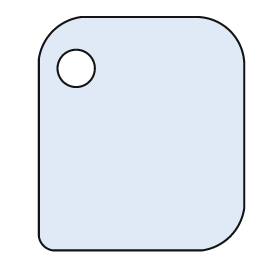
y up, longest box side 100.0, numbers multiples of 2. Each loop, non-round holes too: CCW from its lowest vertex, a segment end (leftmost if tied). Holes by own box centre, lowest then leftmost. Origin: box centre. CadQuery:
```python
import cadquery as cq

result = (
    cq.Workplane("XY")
    .moveTo(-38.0, -50.0)
    .lineTo(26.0, -50.0)
    .threePointArc((38.0, -44.0), (44.0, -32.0))
    .lineTo(44.0, 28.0)
    .threePointArc((38.0, 44.0), (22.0, 50.0))
    .lineTo(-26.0, 50.0)
    .threePointArc((-38.0, 44.0), (-44.0, 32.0))
    .lineTo(-44.0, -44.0)
    .threePointArc((-42.0, -48.0), (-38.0, -50.0))
    .close()
    .moveTo(-28.0, 28.0)
    .circle(8.0)
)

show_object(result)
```